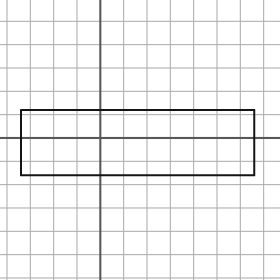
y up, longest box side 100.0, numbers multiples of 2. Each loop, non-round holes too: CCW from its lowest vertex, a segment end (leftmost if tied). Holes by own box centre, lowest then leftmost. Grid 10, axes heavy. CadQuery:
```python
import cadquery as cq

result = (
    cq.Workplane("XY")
    .moveTo(-34.0, -16.0)
    .lineTo(66.0, -16.0)
    .lineTo(66.0, 12.0)
    .lineTo(-34.0, 12.0)
    .close()
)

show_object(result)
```